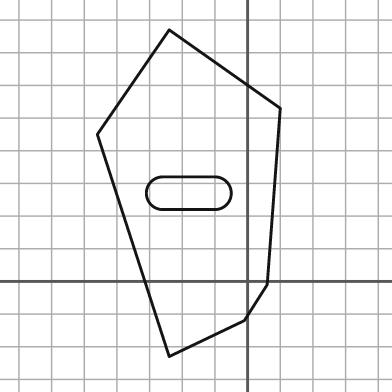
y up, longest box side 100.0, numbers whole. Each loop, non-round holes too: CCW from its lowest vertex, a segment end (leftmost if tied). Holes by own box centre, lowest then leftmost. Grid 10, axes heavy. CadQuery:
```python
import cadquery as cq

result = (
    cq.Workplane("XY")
    .moveTo(-24.0, -23.0)
    .lineTo(-1.0, -12.0)
    .lineTo(6.0, -1.0)
    .lineTo(10.0, 53.0)
    .lineTo(-24.0, 77.0)
    .lineTo(-46.0, 45.0)
    .close()
    .moveTo(-26.0, 22.0)
    .lineTo(-10.0, 22.0)
    .threePointArc((-5.0, 27.0), (-10.0, 32.0))
    .lineTo(-26.0, 32.0)
    .threePointArc((-31.0, 27.0), (-26.0, 22.0))
    .close()
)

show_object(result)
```